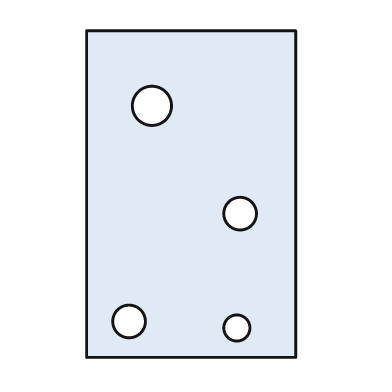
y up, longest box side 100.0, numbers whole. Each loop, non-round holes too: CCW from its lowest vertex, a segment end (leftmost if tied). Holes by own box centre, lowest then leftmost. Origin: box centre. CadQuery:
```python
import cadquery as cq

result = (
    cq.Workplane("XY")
    .moveTo(-32.0, -50.0)
    .lineTo(32.0, -50.0)
    .lineTo(32.0, 50.0)
    .lineTo(-32.0, 50.0)
    .close()
    .moveTo(14.0, -41.0)
    .circle(4.0)
    .moveTo(-19.0, -39.0)
    .circle(5.0)
    .moveTo(15.0, -6.0)
    .circle(5.0)
    .moveTo(-12.0, 27.0)
    .circle(6.0)
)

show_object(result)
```